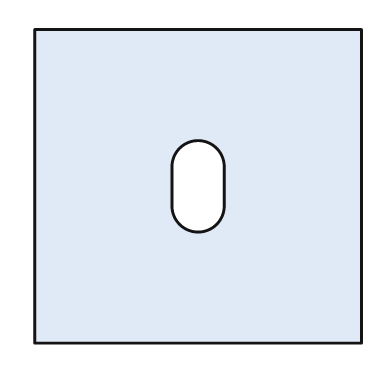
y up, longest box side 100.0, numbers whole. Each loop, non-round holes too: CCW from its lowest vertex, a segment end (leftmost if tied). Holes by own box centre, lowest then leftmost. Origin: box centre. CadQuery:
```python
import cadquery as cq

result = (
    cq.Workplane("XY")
    .moveTo(-50.0, -48.0)
    .lineTo(50.0, -48.0)
    .lineTo(50.0, 48.0)
    .lineTo(-50.0, 48.0)
    .close()
    .moveTo(-8.0, -6.0)
    .threePointArc((0.0, -14.0), (8.0, -6.0))
    .lineTo(8.0, 6.0)
    .threePointArc((0.0, 14.0), (-8.0, 6.0))
    .close()
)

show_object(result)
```